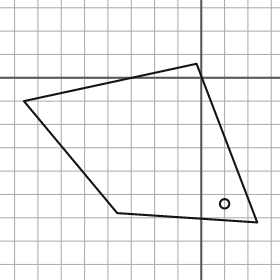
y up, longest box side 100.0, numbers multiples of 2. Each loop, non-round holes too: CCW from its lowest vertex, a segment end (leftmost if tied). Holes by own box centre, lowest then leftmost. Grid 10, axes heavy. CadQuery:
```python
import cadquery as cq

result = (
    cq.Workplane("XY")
    .moveTo(24.0, -62.0)
    .lineTo(-2.0, 6.0)
    .lineTo(-76.0, -10.0)
    .lineTo(-36.0, -58.0)
    .close()
    .moveTo(10.0, -54.0)
    .circle(2.0)
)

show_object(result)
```